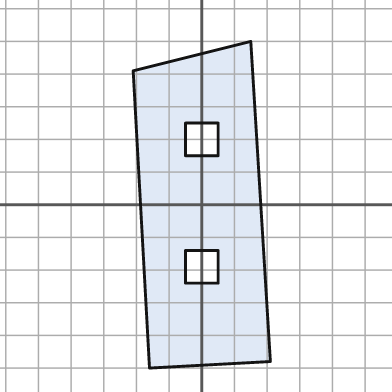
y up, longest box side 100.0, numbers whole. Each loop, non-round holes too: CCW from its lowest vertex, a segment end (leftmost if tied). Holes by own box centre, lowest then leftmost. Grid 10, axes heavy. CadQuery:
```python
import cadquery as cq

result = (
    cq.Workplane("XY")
    .moveTo(-16.0, -50.0)
    .lineTo(21.0, -48.0)
    .lineTo(15.0, 50.0)
    .lineTo(-21.0, 41.0)
    .close()
    .moveTo(-5.0, -24.0)
    .lineTo(5.0, -24.0)
    .lineTo(5.0, -14.0)
    .lineTo(-5.0, -14.0)
    .close()
    .moveTo(-5.0, 15.0)
    .lineTo(5.0, 15.0)
    .lineTo(5.0, 25.0)
    .lineTo(-5.0, 25.0)
    .close()
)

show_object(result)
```